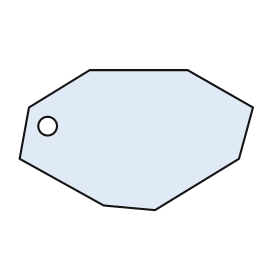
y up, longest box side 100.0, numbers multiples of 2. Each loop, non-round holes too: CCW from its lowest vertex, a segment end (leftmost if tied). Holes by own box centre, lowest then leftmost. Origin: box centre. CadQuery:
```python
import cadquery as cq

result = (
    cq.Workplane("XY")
    .moveTo(8.0, -30.0)
    .lineTo(44.0, -8.0)
    .lineTo(50.0, 14.0)
    .lineTo(22.0, 30.0)
    .lineTo(-20.0, 30.0)
    .lineTo(-46.0, 14.0)
    .lineTo(-50.0, -8.0)
    .lineTo(-14.0, -28.0)
    .close()
    .moveTo(-38.0, 6.0)
    .circle(4.0)
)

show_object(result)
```